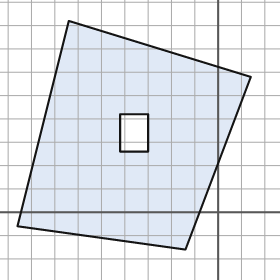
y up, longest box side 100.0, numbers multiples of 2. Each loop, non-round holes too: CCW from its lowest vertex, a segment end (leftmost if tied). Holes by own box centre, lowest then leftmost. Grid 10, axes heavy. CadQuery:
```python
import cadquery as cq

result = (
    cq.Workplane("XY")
    .moveTo(-14.0, -16.0)
    .lineTo(14.0, 58.0)
    .lineTo(-64.0, 82.0)
    .lineTo(-86.0, -6.0)
    .close()
    .moveTo(-42.0, 26.0)
    .lineTo(-30.0, 26.0)
    .lineTo(-30.0, 42.0)
    .lineTo(-42.0, 42.0)
    .close()
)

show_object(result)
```